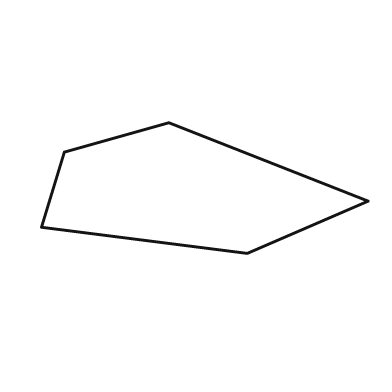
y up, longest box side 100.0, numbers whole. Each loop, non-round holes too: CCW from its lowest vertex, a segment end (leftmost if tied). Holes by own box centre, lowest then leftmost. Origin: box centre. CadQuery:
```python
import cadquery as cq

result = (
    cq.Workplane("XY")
    .moveTo(13.0, -20.0)
    .lineTo(50.0, -4.0)
    .lineTo(-11.0, 20.0)
    .lineTo(-43.0, 11.0)
    .lineTo(-50.0, -12.0)
    .close()
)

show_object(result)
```